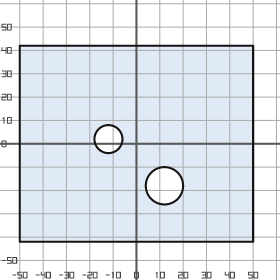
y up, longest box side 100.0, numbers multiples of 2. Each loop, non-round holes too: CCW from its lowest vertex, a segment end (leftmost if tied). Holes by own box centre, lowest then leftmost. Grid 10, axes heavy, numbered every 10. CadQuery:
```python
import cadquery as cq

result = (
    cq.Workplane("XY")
    .moveTo(-50.0, -42.0)
    .lineTo(50.0, -42.0)
    .lineTo(50.0, 42.0)
    .lineTo(-50.0, 42.0)
    .close()
    .moveTo(12.0, -18.0)
    .circle(8.0)
    .moveTo(-12.0, 2.0)
    .circle(6.0)
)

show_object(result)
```